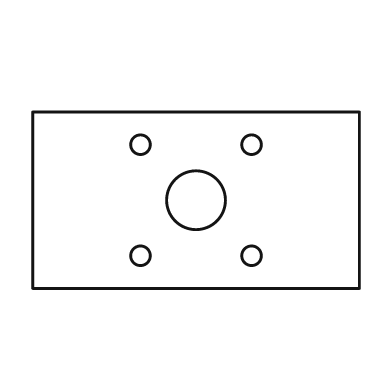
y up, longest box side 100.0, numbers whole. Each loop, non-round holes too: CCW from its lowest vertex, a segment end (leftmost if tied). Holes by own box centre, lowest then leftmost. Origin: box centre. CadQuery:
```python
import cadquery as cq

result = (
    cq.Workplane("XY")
    .moveTo(-50.0, -27.0)
    .lineTo(50.0, -27.0)
    .lineTo(50.0, 27.0)
    .lineTo(-50.0, 27.0)
    .close()
    .moveTo(-17.0, -17.0)
    .circle(3.0)
    .moveTo(17.0, -17.0)
    .circle(3.0)
    .moveTo(0.0, 0.0)
    .circle(9.0)
    .moveTo(-17.0, 17.0)
    .circle(3.0)
    .moveTo(17.0, 17.0)
    .circle(3.0)
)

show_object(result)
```